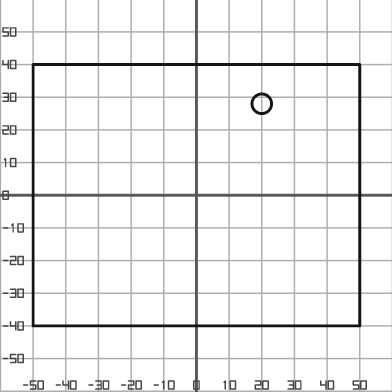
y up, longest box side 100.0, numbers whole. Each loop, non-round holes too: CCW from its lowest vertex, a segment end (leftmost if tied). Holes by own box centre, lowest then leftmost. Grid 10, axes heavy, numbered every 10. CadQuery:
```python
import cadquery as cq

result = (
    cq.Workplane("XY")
    .moveTo(-50.0, -40.0)
    .lineTo(50.0, -40.0)
    .lineTo(50.0, 40.0)
    .lineTo(-50.0, 40.0)
    .close()
    .moveTo(20.0, 28.0)
    .circle(3.0)
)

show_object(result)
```